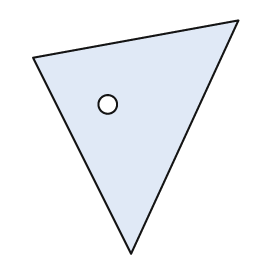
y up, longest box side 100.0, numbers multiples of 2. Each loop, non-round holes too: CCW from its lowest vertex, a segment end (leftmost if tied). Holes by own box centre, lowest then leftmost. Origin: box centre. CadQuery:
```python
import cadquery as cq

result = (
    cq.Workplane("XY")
    .moveTo(-2.0, -50.0)
    .lineTo(44.0, 50.0)
    .lineTo(-44.0, 34.0)
    .close()
    .moveTo(-12.0, 14.0)
    .circle(4.0)
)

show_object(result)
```